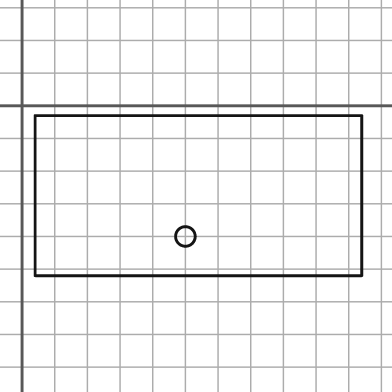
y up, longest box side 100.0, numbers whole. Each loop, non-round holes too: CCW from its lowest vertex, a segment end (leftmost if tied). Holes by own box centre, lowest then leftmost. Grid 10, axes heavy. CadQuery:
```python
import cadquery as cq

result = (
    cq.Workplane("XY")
    .moveTo(4.0, -52.0)
    .lineTo(104.0, -52.0)
    .lineTo(104.0, -3.0)
    .lineTo(4.0, -3.0)
    .close()
    .moveTo(50.0, -40.0)
    .circle(3.0)
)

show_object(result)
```